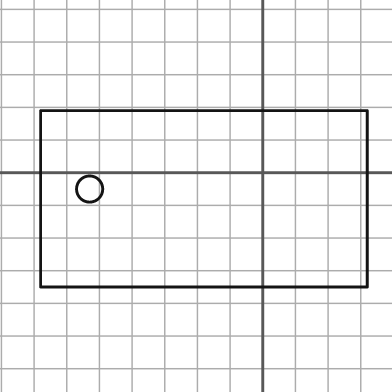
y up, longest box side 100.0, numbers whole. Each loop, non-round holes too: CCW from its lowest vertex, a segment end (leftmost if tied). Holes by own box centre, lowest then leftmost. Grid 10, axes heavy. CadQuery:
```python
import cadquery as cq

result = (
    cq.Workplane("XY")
    .moveTo(-68.0, -35.0)
    .lineTo(32.0, -35.0)
    .lineTo(32.0, 19.0)
    .lineTo(-68.0, 19.0)
    .close()
    .moveTo(-53.0, -5.0)
    .circle(4.0)
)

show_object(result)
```